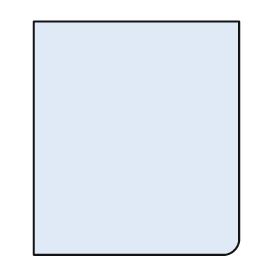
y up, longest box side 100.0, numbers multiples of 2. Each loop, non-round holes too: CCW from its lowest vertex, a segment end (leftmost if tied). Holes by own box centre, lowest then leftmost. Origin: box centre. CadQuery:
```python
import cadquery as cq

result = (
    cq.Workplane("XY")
    .moveTo(-44.0, -50.0)
    .lineTo(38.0, -50.0)
    .threePointArc((42.0, -48.0), (44.0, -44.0))
    .lineTo(44.0, 50.0)
    .lineTo(-44.0, 50.0)
    .close()
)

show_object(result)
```